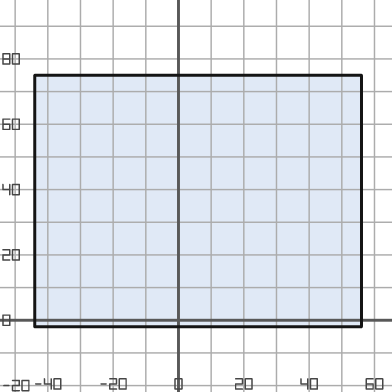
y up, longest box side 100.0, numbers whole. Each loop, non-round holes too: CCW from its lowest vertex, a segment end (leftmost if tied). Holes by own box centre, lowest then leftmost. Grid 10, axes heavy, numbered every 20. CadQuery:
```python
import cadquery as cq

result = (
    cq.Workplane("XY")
    .moveTo(-44.0, -2.0)
    .lineTo(56.0, -2.0)
    .lineTo(56.0, 75.0)
    .lineTo(-44.0, 75.0)
    .close()
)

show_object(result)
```